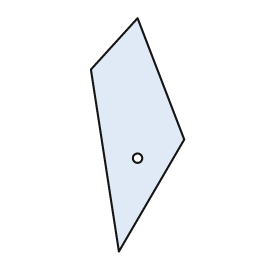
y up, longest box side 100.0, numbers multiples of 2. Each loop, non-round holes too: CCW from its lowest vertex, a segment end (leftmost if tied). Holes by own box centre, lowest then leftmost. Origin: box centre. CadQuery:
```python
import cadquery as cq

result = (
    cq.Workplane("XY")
    .moveTo(-8.0, -50.0)
    .lineTo(20.0, -2.0)
    .lineTo(0.0, 50.0)
    .lineTo(-20.0, 28.0)
    .close()
    .moveTo(0.0, -10.0)
    .circle(2.0)
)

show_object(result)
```